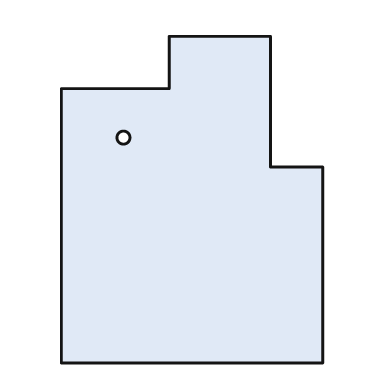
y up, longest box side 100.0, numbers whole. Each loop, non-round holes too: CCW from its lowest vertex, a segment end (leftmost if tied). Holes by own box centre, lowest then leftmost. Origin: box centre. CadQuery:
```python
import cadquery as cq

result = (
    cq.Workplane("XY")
    .moveTo(-40.0, -50.0)
    .lineTo(40.0, -50.0)
    .lineTo(40.0, 10.0)
    .lineTo(24.0, 10.0)
    .lineTo(24.0, 50.0)
    .lineTo(-7.0, 50.0)
    .lineTo(-7.0, 34.0)
    .lineTo(-40.0, 34.0)
    .close()
    .moveTo(-21.0, 19.0)
    .circle(2.0)
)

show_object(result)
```